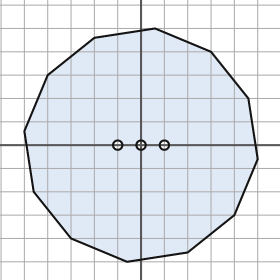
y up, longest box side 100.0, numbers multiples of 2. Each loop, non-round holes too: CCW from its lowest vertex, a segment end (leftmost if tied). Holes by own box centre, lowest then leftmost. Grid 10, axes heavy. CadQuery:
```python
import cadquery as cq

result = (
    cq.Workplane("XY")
    .moveTo(-6.0, -50.0)
    .lineTo(20.0, -46.0)
    .lineTo(40.0, -30.0)
    .lineTo(50.0, -6.0)
    .lineTo(46.0, 20.0)
    .lineTo(30.0, 40.0)
    .lineTo(6.0, 50.0)
    .lineTo(-20.0, 46.0)
    .lineTo(-40.0, 30.0)
    .lineTo(-50.0, 6.0)
    .lineTo(-46.0, -20.0)
    .lineTo(-30.0, -40.0)
    .close()
    .moveTo(-10.0, 0.0)
    .circle(2.0)
    .moveTo(0.0, 0.0)
    .circle(2.0)
    .moveTo(10.0, 0.0)
    .circle(2.0)
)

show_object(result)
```